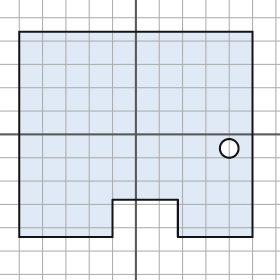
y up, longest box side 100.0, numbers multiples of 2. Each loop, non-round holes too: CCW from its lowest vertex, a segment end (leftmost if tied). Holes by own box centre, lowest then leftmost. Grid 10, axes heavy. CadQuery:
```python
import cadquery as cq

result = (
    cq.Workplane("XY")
    .moveTo(-50.0, -44.0)
    .lineTo(-10.0, -44.0)
    .lineTo(-10.0, -28.0)
    .lineTo(18.0, -28.0)
    .lineTo(18.0, -44.0)
    .lineTo(50.0, -44.0)
    .lineTo(50.0, 44.0)
    .lineTo(-50.0, 44.0)
    .close()
    .moveTo(40.0, -6.0)
    .circle(4.0)
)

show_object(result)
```